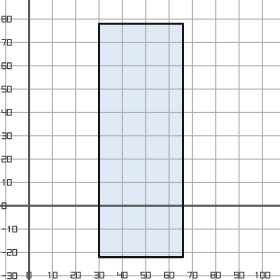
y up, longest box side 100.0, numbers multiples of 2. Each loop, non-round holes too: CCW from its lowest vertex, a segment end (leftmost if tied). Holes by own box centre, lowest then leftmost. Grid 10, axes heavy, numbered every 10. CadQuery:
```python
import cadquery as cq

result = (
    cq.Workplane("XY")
    .moveTo(30.0, -22.0)
    .lineTo(66.0, -22.0)
    .lineTo(66.0, 78.0)
    .lineTo(30.0, 78.0)
    .close()
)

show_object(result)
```